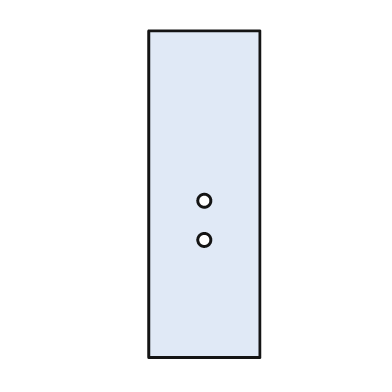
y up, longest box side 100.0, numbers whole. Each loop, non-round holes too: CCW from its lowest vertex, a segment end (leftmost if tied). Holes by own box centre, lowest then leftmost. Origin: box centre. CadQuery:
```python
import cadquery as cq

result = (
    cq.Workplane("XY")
    .moveTo(-17.0, -50.0)
    .lineTo(17.0, -50.0)
    .lineTo(17.0, 50.0)
    .lineTo(-17.0, 50.0)
    .close()
    .moveTo(0.0, -14.0)
    .circle(2.0)
    .moveTo(0.0, -2.0)
    .circle(2.0)
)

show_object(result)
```